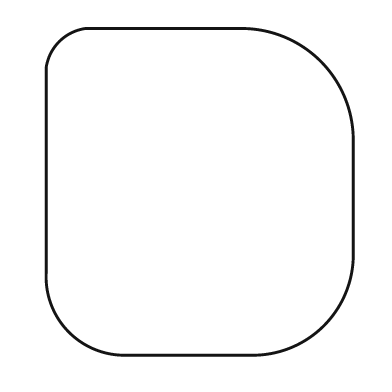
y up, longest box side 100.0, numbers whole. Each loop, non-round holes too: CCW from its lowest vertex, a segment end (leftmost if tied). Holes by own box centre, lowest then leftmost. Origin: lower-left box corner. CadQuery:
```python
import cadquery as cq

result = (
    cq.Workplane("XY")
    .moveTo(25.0, 0.0)
    .lineTo(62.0, 0.0)
    .threePointArc((85.0, 9.0), (94.0, 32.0))
    .lineTo(94.0, 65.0)
    .threePointArc((84.0, 90.0), (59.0, 100.0))
    .lineTo(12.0, 100.0)
    .threePointArc((4.0, 96.0), (0.0, 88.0))
    .lineTo(0.0, 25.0)
    .threePointArc((7.0, 7.0), (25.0, 0.0))
    .close()
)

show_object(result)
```